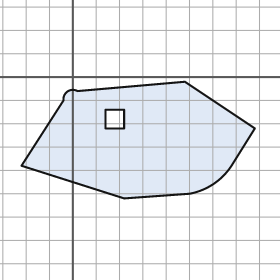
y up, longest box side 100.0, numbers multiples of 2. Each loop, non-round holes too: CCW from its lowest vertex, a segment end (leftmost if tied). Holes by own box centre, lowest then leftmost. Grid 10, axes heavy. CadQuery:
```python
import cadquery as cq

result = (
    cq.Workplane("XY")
    .moveTo(22.0, -52.0)
    .lineTo(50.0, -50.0)
    .threePointArc((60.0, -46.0), (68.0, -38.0))
    .lineTo(78.0, -22.0)
    .lineTo(48.0, -2.0)
    .lineTo(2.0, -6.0)
    .threePointArc((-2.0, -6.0), (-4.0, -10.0))
    .lineTo(-22.0, -38.0)
    .close()
    .moveTo(14.0, -22.0)
    .lineTo(22.0, -22.0)
    .lineTo(22.0, -14.0)
    .lineTo(14.0, -14.0)
    .close()
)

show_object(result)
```